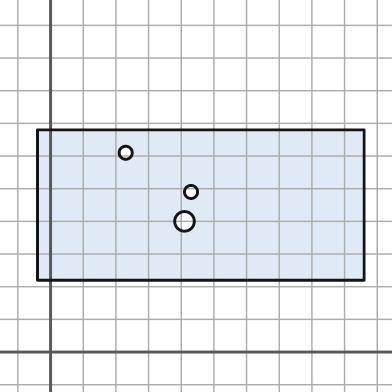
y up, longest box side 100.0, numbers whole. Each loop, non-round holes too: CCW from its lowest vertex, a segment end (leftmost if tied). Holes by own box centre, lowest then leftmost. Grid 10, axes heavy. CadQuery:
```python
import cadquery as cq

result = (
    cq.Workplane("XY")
    .moveTo(-4.0, 22.0)
    .lineTo(96.0, 22.0)
    .lineTo(96.0, 68.0)
    .lineTo(-4.0, 68.0)
    .close()
    .moveTo(41.0, 40.0)
    .circle(3.0)
    .moveTo(43.0, 49.0)
    .circle(2.0)
    .moveTo(23.0, 61.0)
    .circle(2.0)
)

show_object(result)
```